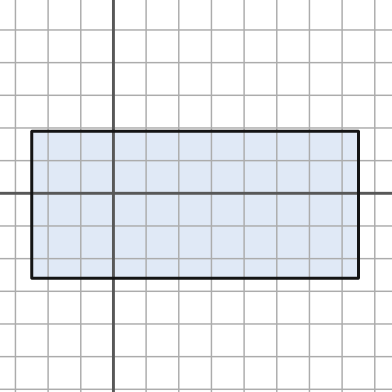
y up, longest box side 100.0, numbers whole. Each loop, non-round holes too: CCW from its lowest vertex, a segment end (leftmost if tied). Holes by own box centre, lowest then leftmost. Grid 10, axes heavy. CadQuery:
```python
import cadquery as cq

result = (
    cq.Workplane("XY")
    .moveTo(-25.0, -26.0)
    .lineTo(75.0, -26.0)
    .lineTo(75.0, 19.0)
    .lineTo(-25.0, 19.0)
    .close()
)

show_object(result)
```